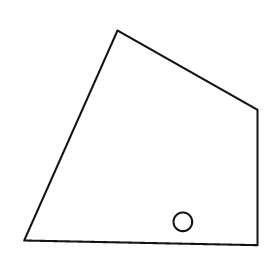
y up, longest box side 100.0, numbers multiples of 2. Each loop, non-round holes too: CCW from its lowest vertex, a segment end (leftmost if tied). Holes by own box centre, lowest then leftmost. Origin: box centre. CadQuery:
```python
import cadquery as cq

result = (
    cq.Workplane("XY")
    .moveTo(50.0, -46.0)
    .lineTo(50.0, 12.0)
    .lineTo(-10.0, 46.0)
    .lineTo(-50.0, -44.0)
    .close()
    .moveTo(18.0, -36.0)
    .circle(4.0)
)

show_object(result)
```